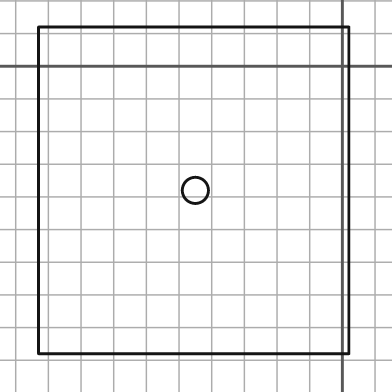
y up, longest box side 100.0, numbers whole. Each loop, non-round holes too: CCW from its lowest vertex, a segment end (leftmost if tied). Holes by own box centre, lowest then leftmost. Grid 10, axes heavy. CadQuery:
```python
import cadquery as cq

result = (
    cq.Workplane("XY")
    .moveTo(-93.0, -88.0)
    .lineTo(2.0, -88.0)
    .lineTo(2.0, 12.0)
    .lineTo(-93.0, 12.0)
    .close()
    .moveTo(-45.0, -38.0)
    .circle(4.0)
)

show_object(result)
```